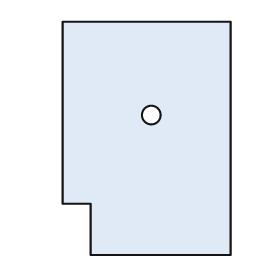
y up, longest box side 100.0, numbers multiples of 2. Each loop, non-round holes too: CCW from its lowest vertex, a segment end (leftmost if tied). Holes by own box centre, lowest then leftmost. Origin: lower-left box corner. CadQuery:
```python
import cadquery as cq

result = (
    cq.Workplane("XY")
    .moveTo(12.0, 0.0)
    .lineTo(72.0, 0.0)
    .lineTo(72.0, 100.0)
    .lineTo(0.0, 100.0)
    .lineTo(0.0, 22.0)
    .lineTo(12.0, 22.0)
    .close()
    .moveTo(38.0, 60.0)
    .circle(4.0)
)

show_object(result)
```